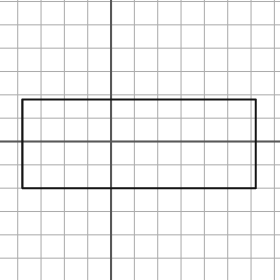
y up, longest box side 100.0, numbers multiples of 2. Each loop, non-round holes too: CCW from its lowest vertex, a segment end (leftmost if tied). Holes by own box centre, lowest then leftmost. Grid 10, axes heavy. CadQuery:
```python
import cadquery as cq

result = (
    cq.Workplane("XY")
    .moveTo(-38.0, -20.0)
    .lineTo(62.0, -20.0)
    .lineTo(62.0, 18.0)
    .lineTo(-38.0, 18.0)
    .close()
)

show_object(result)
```